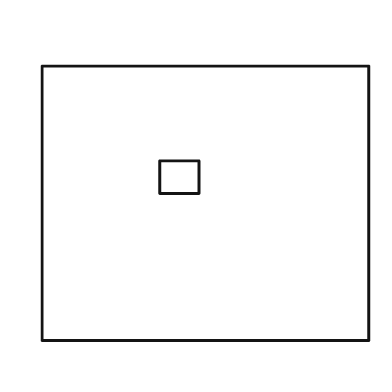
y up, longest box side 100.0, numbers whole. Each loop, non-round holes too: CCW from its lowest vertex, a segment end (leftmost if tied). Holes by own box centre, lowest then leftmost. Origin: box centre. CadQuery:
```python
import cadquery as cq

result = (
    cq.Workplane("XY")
    .moveTo(-50.0, -42.0)
    .lineTo(50.0, -42.0)
    .lineTo(50.0, 42.0)
    .lineTo(-50.0, 42.0)
    .close()
    .moveTo(-14.0, 3.0)
    .lineTo(-2.0, 3.0)
    .lineTo(-2.0, 13.0)
    .lineTo(-14.0, 13.0)
    .close()
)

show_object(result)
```